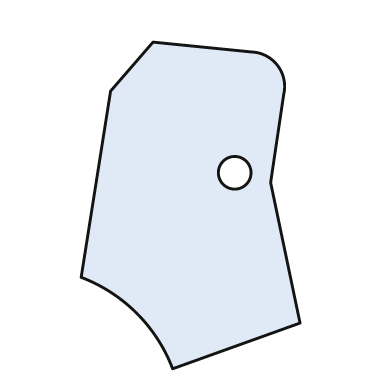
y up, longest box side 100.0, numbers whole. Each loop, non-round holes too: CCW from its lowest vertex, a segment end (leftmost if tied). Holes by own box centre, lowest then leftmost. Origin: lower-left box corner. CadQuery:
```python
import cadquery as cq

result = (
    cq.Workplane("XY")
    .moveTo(28.0, 0.0)
    .lineTo(67.0, 14.0)
    .lineTo(58.0, 57.0)
    .lineTo(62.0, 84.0)
    .threePointArc((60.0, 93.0), (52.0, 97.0))
    .lineTo(22.0, 100.0)
    .lineTo(9.0, 85.0)
    .lineTo(0.0, 28.0)
    .threePointArc((17.0, 17.0), (28.0, 0.0))
    .close()
    .moveTo(47.0, 60.0)
    .circle(5.0)
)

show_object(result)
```